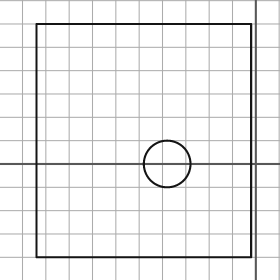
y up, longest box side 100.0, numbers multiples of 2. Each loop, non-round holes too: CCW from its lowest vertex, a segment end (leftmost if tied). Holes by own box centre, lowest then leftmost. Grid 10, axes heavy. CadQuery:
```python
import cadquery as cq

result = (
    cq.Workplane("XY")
    .moveTo(-94.0, -40.0)
    .lineTo(-2.0, -40.0)
    .lineTo(-2.0, 60.0)
    .lineTo(-94.0, 60.0)
    .close()
    .moveTo(-38.0, 0.0)
    .circle(10.0)
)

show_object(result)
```